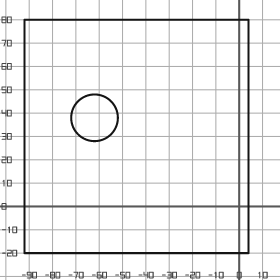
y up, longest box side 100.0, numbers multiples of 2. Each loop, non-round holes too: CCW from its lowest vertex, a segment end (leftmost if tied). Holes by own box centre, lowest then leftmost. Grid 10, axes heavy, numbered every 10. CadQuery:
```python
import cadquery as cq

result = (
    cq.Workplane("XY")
    .moveTo(-92.0, -20.0)
    .lineTo(4.0, -20.0)
    .lineTo(4.0, 80.0)
    .lineTo(-92.0, 80.0)
    .close()
    .moveTo(-62.0, 38.0)
    .circle(10.0)
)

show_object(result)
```